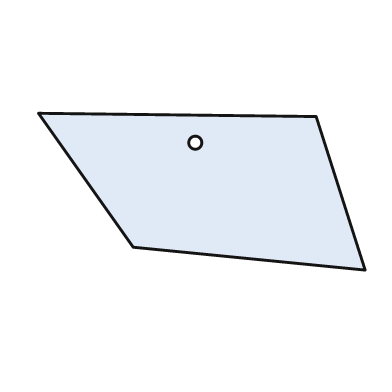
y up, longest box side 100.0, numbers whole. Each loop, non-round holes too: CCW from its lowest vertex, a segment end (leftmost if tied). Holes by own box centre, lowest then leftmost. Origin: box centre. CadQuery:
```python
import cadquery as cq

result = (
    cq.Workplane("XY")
    .moveTo(50.0, -24.0)
    .lineTo(35.0, 23.0)
    .lineTo(-50.0, 24.0)
    .lineTo(-21.0, -17.0)
    .close()
    .moveTo(-2.0, 15.0)
    .circle(2.0)
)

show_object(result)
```